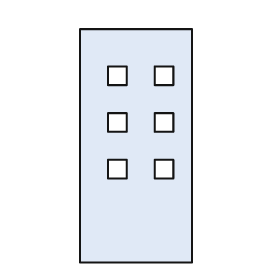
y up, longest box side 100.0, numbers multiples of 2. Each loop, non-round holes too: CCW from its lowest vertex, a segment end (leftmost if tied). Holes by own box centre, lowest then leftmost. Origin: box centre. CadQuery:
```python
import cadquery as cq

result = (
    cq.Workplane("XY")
    .moveTo(-24.0, -50.0)
    .lineTo(24.0, -50.0)
    .lineTo(24.0, 50.0)
    .lineTo(-24.0, 50.0)
    .close()
    .moveTo(-12.0, -14.0)
    .lineTo(-4.0, -14.0)
    .lineTo(-4.0, -6.0)
    .lineTo(-12.0, -6.0)
    .close()
    .moveTo(8.0, -14.0)
    .lineTo(16.0, -14.0)
    .lineTo(16.0, -6.0)
    .lineTo(8.0, -6.0)
    .close()
    .moveTo(-12.0, 6.0)
    .lineTo(-4.0, 6.0)
    .lineTo(-4.0, 14.0)
    .lineTo(-12.0, 14.0)
    .close()
    .moveTo(8.0, 6.0)
    .lineTo(16.0, 6.0)
    .lineTo(16.0, 14.0)
    .lineTo(8.0, 14.0)
    .close()
    .moveTo(-12.0, 26.0)
    .lineTo(-4.0, 26.0)
    .lineTo(-4.0, 34.0)
    .lineTo(-12.0, 34.0)
    .close()
    .moveTo(8.0, 26.0)
    .lineTo(16.0, 26.0)
    .lineTo(16.0, 34.0)
    .lineTo(8.0, 34.0)
    .close()
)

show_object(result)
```